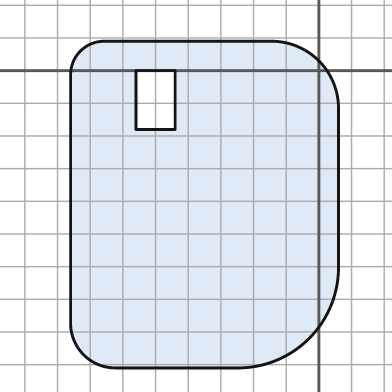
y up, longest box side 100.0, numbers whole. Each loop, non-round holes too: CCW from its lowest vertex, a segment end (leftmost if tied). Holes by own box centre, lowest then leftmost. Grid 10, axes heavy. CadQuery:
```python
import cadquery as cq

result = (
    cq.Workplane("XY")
    .moveTo(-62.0, -91.0)
    .lineTo(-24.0, -91.0)
    .threePointArc((-3.0, -82.0), (6.0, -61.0))
    .lineTo(6.0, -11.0)
    .threePointArc((0.0, 3.0), (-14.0, 9.0))
    .lineTo(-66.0, 9.0)
    .threePointArc((-73.0, 6.0), (-76.0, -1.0))
    .lineTo(-76.0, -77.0)
    .threePointArc((-72.0, -87.0), (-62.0, -91.0))
    .close()
    .moveTo(-56.0, -18.0)
    .lineTo(-44.0, -18.0)
    .lineTo(-44.0, 0.0)
    .lineTo(-56.0, 0.0)
    .close()
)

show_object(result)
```